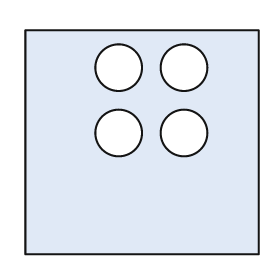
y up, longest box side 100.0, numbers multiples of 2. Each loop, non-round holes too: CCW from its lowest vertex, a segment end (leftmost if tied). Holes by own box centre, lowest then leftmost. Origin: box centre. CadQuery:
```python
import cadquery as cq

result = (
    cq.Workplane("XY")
    .moveTo(-50.0, -48.0)
    .lineTo(50.0, -48.0)
    .lineTo(50.0, 48.0)
    .lineTo(-50.0, 48.0)
    .close()
    .moveTo(-10.0, 4.0)
    .circle(10.0)
    .moveTo(18.0, 4.0)
    .circle(10.0)
    .moveTo(-10.0, 32.0)
    .circle(10.0)
    .moveTo(18.0, 32.0)
    .circle(10.0)
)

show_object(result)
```